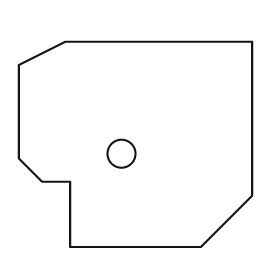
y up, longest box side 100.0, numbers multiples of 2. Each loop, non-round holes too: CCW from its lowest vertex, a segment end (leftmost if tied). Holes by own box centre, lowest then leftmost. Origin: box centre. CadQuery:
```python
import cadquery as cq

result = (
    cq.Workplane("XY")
    .moveTo(-28.0, -44.0)
    .lineTo(28.0, -44.0)
    .lineTo(50.0, -22.0)
    .lineTo(50.0, 44.0)
    .lineTo(-30.0, 44.0)
    .lineTo(-50.0, 34.0)
    .lineTo(-50.0, -6.0)
    .lineTo(-40.0, -16.0)
    .lineTo(-28.0, -16.0)
    .close()
    .moveTo(-6.0, -4.0)
    .circle(6.0)
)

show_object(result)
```